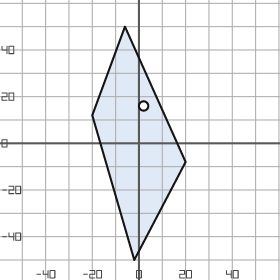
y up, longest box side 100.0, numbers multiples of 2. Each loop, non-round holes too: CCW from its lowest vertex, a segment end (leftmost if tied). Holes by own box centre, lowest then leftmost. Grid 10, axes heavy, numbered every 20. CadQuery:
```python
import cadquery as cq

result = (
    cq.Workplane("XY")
    .moveTo(-2.0, -50.0)
    .lineTo(20.0, -8.0)
    .lineTo(-6.0, 50.0)
    .lineTo(-20.0, 12.0)
    .close()
    .moveTo(2.0, 16.0)
    .circle(2.0)
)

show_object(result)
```